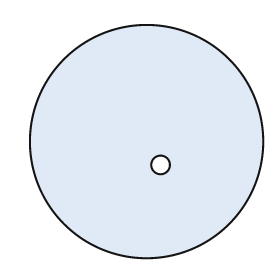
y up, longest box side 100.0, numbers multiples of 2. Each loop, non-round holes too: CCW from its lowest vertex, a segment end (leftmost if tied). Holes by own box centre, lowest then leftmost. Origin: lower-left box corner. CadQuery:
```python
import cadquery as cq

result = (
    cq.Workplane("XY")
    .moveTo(50.0, 50.0)
    .circle(50.0)
    .moveTo(56.0, 40.0)
    .circle(4.0)
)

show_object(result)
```